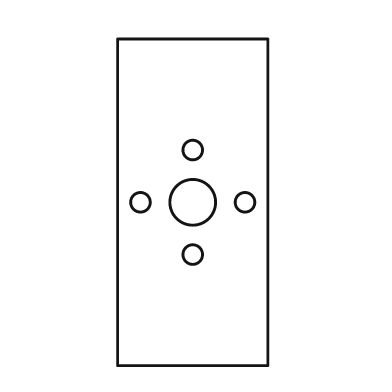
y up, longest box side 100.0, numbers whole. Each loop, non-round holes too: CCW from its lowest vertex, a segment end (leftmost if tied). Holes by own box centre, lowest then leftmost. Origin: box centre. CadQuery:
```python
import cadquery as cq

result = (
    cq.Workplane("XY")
    .moveTo(-23.0, -50.0)
    .lineTo(23.0, -50.0)
    .lineTo(23.0, 50.0)
    .lineTo(-23.0, 50.0)
    .close()
    .moveTo(0.0, -16.0)
    .circle(3.0)
    .moveTo(-16.0, 0.0)
    .circle(3.0)
    .moveTo(0.0, 0.0)
    .circle(7.0)
    .moveTo(16.0, 0.0)
    .circle(3.0)
    .moveTo(0.0, 16.0)
    .circle(3.0)
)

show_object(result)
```